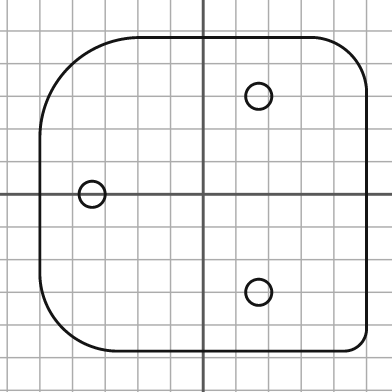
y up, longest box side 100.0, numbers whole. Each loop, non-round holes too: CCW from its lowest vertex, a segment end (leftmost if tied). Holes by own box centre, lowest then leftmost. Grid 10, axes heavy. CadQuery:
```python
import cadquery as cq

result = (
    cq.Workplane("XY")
    .moveTo(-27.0, -48.0)
    .lineTo(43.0, -48.0)
    .threePointArc((48.0, -46.0), (50.0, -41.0))
    .lineTo(50.0, 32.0)
    .threePointArc((45.0, 43.0), (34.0, 48.0))
    .lineTo(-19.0, 48.0)
    .threePointArc((-41.0, 39.0), (-50.0, 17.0))
    .lineTo(-50.0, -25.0)
    .threePointArc((-43.0, -41.0), (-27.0, -48.0))
    .close()
    .moveTo(17.0, -30.0)
    .circle(4.0)
    .moveTo(-34.0, 0.0)
    .circle(4.0)
    .moveTo(17.0, 30.0)
    .circle(4.0)
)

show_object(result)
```